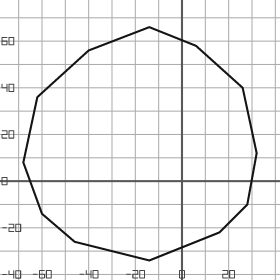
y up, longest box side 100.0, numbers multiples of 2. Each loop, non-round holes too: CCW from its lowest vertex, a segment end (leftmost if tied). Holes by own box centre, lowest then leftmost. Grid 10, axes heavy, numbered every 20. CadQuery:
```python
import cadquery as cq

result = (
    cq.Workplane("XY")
    .moveTo(-14.0, -34.0)
    .lineTo(16.0, -22.0)
    .lineTo(28.0, -10.0)
    .lineTo(32.0, 12.0)
    .lineTo(26.0, 40.0)
    .lineTo(6.0, 58.0)
    .lineTo(-14.0, 66.0)
    .lineTo(-40.0, 56.0)
    .lineTo(-62.0, 36.0)
    .lineTo(-68.0, 8.0)
    .lineTo(-60.0, -14.0)
    .lineTo(-46.0, -26.0)
    .close()
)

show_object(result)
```